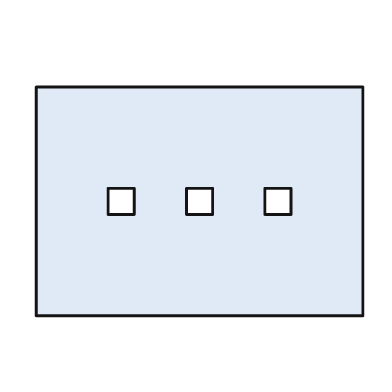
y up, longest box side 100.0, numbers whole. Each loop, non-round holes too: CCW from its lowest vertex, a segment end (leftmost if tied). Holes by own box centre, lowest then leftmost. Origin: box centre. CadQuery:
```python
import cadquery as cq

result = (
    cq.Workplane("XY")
    .moveTo(-50.0, -35.0)
    .lineTo(50.0, -35.0)
    .lineTo(50.0, 35.0)
    .lineTo(-50.0, 35.0)
    .close()
    .moveTo(-28.0, -4.0)
    .lineTo(-20.0, -4.0)
    .lineTo(-20.0, 4.0)
    .lineTo(-28.0, 4.0)
    .close()
    .moveTo(-4.0, -4.0)
    .lineTo(4.0, -4.0)
    .lineTo(4.0, 4.0)
    .lineTo(-4.0, 4.0)
    .close()
    .moveTo(20.0, -4.0)
    .lineTo(28.0, -4.0)
    .lineTo(28.0, 4.0)
    .lineTo(20.0, 4.0)
    .close()
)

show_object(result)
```